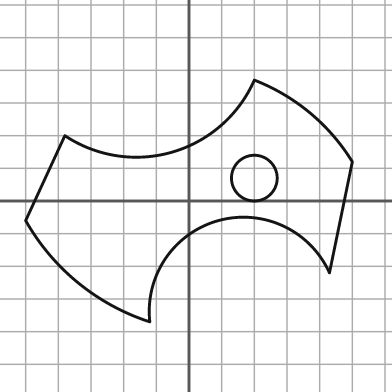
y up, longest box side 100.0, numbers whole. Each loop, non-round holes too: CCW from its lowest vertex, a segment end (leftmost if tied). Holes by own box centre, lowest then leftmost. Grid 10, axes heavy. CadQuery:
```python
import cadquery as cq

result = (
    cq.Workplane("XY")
    .moveTo(-12.0, -37.0)
    .threePointArc((9.0, -6.0), (43.0, -22.0))
    .lineTo(50.0, 12.0)
    .threePointArc((37.0, 27.0), (20.0, 37.0))
    .threePointArc((-5.0, 15.0), (-38.0, 20.0))
    .lineTo(-50.0, -6.0)
    .threePointArc((-34.0, -25.0), (-12.0, -37.0))
    .close()
    .moveTo(20.0, 7.0)
    .circle(7.0)
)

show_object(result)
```